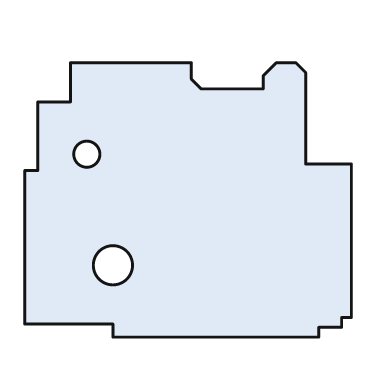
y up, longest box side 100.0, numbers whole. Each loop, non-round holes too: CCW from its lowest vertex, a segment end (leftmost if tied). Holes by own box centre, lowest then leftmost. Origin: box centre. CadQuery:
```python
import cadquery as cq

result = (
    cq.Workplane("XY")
    .moveTo(-23.0, -42.0)
    .lineTo(40.0, -42.0)
    .lineTo(40.0, -39.0)
    .lineTo(47.0, -39.0)
    .lineTo(47.0, -36.0)
    .lineTo(50.0, -36.0)
    .lineTo(50.0, 11.0)
    .lineTo(36.0, 11.0)
    .lineTo(36.0, 39.0)
    .lineTo(33.0, 42.0)
    .lineTo(27.0, 42.0)
    .lineTo(23.0, 38.0)
    .lineTo(23.0, 34.0)
    .lineTo(4.0, 34.0)
    .lineTo(1.0, 37.0)
    .lineTo(1.0, 42.0)
    .lineTo(-36.0, 42.0)
    .lineTo(-36.0, 30.0)
    .lineTo(-46.0, 30.0)
    .lineTo(-46.0, 9.0)
    .lineTo(-50.0, 9.0)
    .lineTo(-50.0, -38.0)
    .lineTo(-23.0, -38.0)
    .close()
    .moveTo(-23.0, -20.0)
    .circle(6.0)
    .moveTo(-31.0, 14.0)
    .circle(4.0)
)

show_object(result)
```